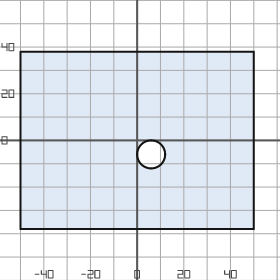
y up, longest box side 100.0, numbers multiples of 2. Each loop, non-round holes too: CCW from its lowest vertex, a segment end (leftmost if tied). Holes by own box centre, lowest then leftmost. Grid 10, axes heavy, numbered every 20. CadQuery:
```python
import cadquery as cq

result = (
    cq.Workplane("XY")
    .moveTo(-50.0, -38.0)
    .lineTo(50.0, -38.0)
    .lineTo(50.0, 38.0)
    .lineTo(-50.0, 38.0)
    .close()
    .moveTo(6.0, -6.0)
    .circle(6.0)
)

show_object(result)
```